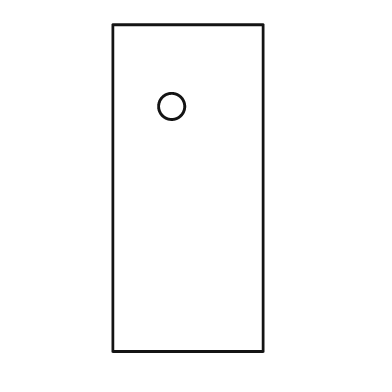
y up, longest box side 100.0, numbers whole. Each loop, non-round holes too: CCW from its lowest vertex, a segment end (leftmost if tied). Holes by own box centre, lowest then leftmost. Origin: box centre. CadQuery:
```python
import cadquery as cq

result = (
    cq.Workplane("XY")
    .moveTo(-23.0, -50.0)
    .lineTo(23.0, -50.0)
    .lineTo(23.0, 50.0)
    .lineTo(-23.0, 50.0)
    .close()
    .moveTo(-5.0, 25.0)
    .circle(4.0)
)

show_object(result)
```